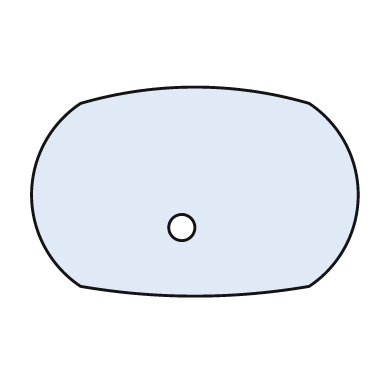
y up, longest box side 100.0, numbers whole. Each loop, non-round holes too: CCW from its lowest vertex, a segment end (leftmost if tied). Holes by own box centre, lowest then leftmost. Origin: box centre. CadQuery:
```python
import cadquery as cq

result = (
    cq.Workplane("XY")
    .moveTo(-35.0, -29.0)
    .threePointArc((0.0, -32.0), (35.0, -29.0))
    .threePointArc((50.0, -1.0), (35.0, 27.0))
    .threePointArc((0.0, 32.0), (-35.0, 27.0))
    .threePointArc((-50.0, -1.0), (-35.0, -29.0))
    .close()
    .moveTo(-4.0, -11.0)
    .circle(4.0)
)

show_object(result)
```